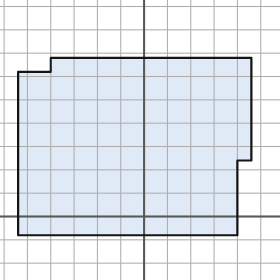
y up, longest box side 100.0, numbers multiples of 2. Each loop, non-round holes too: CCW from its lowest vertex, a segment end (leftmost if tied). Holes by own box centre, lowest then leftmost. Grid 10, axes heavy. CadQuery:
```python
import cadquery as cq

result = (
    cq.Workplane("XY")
    .moveTo(-54.0, -8.0)
    .lineTo(40.0, -8.0)
    .lineTo(40.0, 24.0)
    .lineTo(46.0, 24.0)
    .lineTo(46.0, 68.0)
    .lineTo(-40.0, 68.0)
    .lineTo(-40.0, 62.0)
    .lineTo(-54.0, 62.0)
    .close()
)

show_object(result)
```